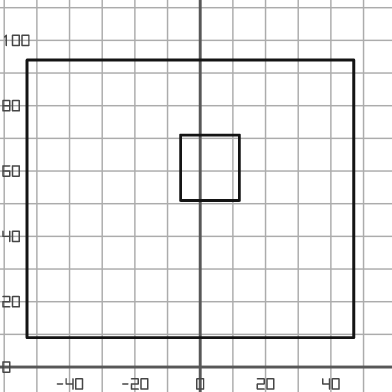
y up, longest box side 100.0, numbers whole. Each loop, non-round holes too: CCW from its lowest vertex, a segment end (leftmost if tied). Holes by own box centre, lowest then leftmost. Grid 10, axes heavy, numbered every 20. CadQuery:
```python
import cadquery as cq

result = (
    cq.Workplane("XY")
    .moveTo(-53.0, 9.0)
    .lineTo(47.0, 9.0)
    .lineTo(47.0, 94.0)
    .lineTo(-53.0, 94.0)
    .close()
    .moveTo(-6.0, 51.0)
    .lineTo(12.0, 51.0)
    .lineTo(12.0, 71.0)
    .lineTo(-6.0, 71.0)
    .close()
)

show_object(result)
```